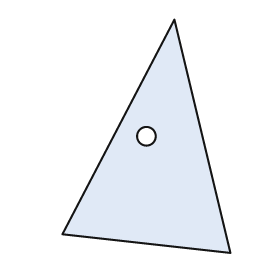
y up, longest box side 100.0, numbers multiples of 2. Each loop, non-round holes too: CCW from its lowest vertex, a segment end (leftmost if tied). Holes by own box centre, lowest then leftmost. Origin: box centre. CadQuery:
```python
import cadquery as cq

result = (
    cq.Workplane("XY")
    .moveTo(36.0, -50.0)
    .lineTo(12.0, 50.0)
    .lineTo(-36.0, -42.0)
    .close()
    .moveTo(0.0, 0.0)
    .circle(4.0)
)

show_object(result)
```